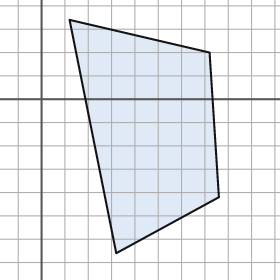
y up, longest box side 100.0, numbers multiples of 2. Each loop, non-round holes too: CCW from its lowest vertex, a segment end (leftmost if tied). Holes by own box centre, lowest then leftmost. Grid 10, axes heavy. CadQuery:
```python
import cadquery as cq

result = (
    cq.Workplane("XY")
    .moveTo(32.0, -66.0)
    .lineTo(76.0, -42.0)
    .lineTo(72.0, 20.0)
    .lineTo(12.0, 34.0)
    .close()
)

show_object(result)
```